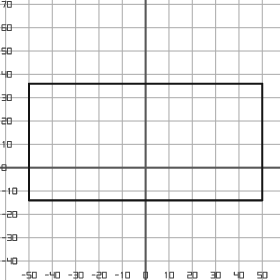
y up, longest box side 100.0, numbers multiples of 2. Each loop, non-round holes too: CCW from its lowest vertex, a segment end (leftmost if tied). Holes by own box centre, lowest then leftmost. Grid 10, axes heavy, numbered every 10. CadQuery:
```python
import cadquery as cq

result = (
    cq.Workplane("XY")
    .moveTo(-50.0, -14.0)
    .lineTo(50.0, -14.0)
    .lineTo(50.0, 36.0)
    .lineTo(-50.0, 36.0)
    .close()
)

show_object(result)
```